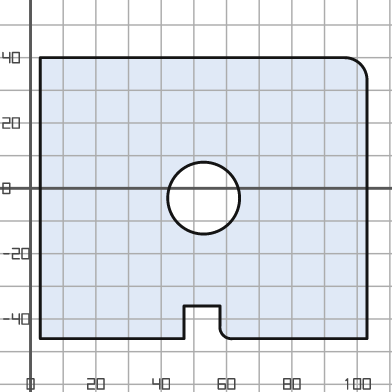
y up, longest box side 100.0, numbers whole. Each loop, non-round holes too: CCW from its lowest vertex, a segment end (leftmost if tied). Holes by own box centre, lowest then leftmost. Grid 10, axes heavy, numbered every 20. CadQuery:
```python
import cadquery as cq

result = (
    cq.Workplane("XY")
    .moveTo(3.0, -46.0)
    .lineTo(47.0, -46.0)
    .lineTo(47.0, -36.0)
    .lineTo(58.0, -36.0)
    .lineTo(58.0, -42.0)
    .threePointArc((59.0, -45.0), (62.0, -46.0))
    .lineTo(103.0, -46.0)
    .lineTo(103.0, 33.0)
    .threePointArc((101.0, 38.0), (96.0, 40.0))
    .lineTo(3.0, 40.0)
    .close()
    .moveTo(53.0, -3.0)
    .circle(11.0)
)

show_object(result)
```